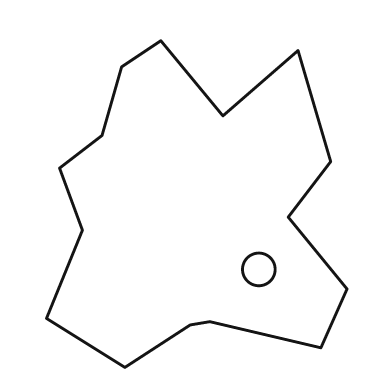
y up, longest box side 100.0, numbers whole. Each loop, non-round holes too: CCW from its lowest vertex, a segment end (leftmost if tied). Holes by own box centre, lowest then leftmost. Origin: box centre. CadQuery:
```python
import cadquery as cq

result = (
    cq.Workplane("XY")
    .moveTo(-22.0, -50.0)
    .lineTo(-2.0, -37.0)
    .lineTo(4.0, -36.0)
    .lineTo(38.0, -44.0)
    .lineTo(46.0, -26.0)
    .lineTo(28.0, -4.0)
    .lineTo(41.0, 13.0)
    .lineTo(31.0, 47.0)
    .lineTo(8.0, 27.0)
    .lineTo(-11.0, 50.0)
    .lineTo(-23.0, 42.0)
    .lineTo(-29.0, 21.0)
    .lineTo(-42.0, 11.0)
    .lineTo(-35.0, -8.0)
    .lineTo(-46.0, -35.0)
    .close()
    .moveTo(19.0, -20.0)
    .circle(5.0)
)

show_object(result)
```